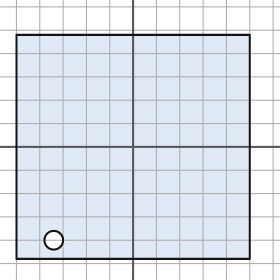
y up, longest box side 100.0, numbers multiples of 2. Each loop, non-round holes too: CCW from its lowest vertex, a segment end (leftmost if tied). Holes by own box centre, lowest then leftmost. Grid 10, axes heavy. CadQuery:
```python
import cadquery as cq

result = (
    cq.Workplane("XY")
    .moveTo(-50.0, -48.0)
    .lineTo(50.0, -48.0)
    .lineTo(50.0, 48.0)
    .lineTo(-50.0, 48.0)
    .close()
    .moveTo(-34.0, -40.0)
    .circle(4.0)
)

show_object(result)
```